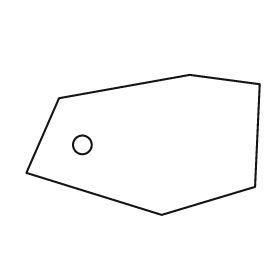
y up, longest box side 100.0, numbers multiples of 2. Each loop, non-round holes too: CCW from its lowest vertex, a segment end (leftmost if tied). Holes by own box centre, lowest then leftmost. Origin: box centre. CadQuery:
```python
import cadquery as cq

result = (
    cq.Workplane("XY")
    .moveTo(8.0, -30.0)
    .lineTo(48.0, -18.0)
    .lineTo(50.0, 26.0)
    .lineTo(20.0, 30.0)
    .lineTo(-36.0, 20.0)
    .lineTo(-50.0, -12.0)
    .close()
    .moveTo(-26.0, 0.0)
    .circle(4.0)
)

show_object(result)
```